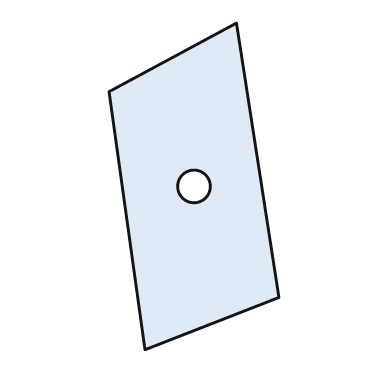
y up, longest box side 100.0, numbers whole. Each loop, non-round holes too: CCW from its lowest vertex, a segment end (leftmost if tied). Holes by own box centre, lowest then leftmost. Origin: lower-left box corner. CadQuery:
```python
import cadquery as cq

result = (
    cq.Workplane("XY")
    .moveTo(11.0, 0.0)
    .lineTo(52.0, 16.0)
    .lineTo(39.0, 100.0)
    .lineTo(0.0, 79.0)
    .close()
    .moveTo(26.0, 50.0)
    .circle(5.0)
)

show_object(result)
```